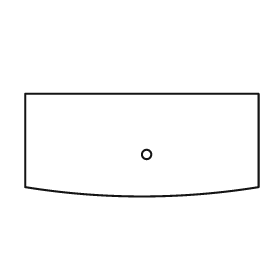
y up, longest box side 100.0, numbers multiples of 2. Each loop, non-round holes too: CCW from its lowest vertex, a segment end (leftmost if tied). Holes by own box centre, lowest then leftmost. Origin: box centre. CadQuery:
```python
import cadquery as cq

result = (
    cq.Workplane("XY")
    .moveTo(-50.0, -18.0)
    .threePointArc((0.0, -22.0), (50.0, -18.0))
    .lineTo(50.0, 22.0)
    .lineTo(-50.0, 22.0)
    .close()
    .moveTo(2.0, -4.0)
    .circle(2.0)
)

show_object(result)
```